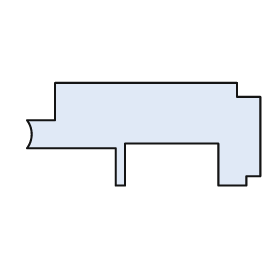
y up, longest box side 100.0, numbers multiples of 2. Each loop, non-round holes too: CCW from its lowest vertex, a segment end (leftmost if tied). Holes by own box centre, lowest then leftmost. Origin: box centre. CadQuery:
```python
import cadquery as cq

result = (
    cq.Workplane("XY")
    .moveTo(-12.0, -22.0)
    .lineTo(-8.0, -22.0)
    .lineTo(-8.0, -4.0)
    .lineTo(32.0, -4.0)
    .lineTo(32.0, -22.0)
    .lineTo(44.0, -22.0)
    .lineTo(44.0, -18.0)
    .lineTo(50.0, -18.0)
    .lineTo(50.0, 16.0)
    .lineTo(40.0, 16.0)
    .lineTo(40.0, 22.0)
    .lineTo(-38.0, 22.0)
    .lineTo(-38.0, 6.0)
    .lineTo(-50.0, 6.0)
    .threePointArc((-48.0, 0.0), (-50.0, -6.0))
    .lineTo(-12.0, -6.0)
    .close()
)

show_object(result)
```